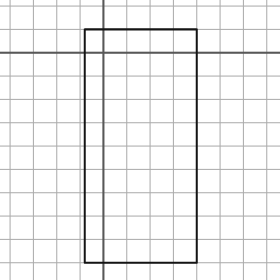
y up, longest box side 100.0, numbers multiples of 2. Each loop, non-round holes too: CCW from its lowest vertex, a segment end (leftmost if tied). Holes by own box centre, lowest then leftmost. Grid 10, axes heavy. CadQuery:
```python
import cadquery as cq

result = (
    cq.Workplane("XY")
    .moveTo(-8.0, -90.0)
    .lineTo(40.0, -90.0)
    .lineTo(40.0, 10.0)
    .lineTo(-8.0, 10.0)
    .close()
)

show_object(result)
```